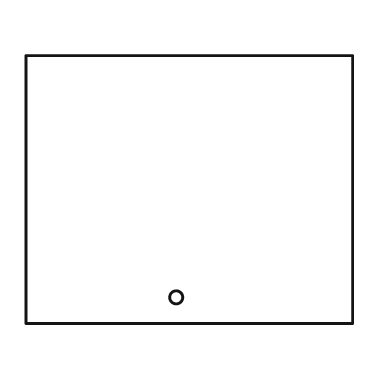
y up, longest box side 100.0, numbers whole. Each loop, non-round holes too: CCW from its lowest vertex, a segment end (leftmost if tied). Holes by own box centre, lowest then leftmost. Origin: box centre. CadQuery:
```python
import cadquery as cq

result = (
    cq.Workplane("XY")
    .moveTo(-50.0, -41.0)
    .lineTo(50.0, -41.0)
    .lineTo(50.0, 41.0)
    .lineTo(-50.0, 41.0)
    .close()
    .moveTo(-4.0, -33.0)
    .circle(2.0)
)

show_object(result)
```